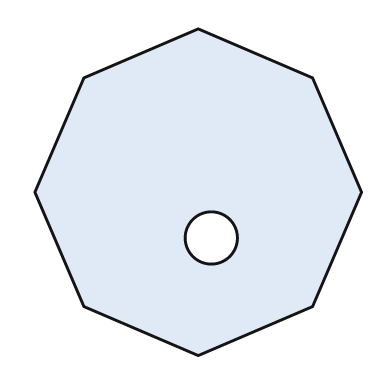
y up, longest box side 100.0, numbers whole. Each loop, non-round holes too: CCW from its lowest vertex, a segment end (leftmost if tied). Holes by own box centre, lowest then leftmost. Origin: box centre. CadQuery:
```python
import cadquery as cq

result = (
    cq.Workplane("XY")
    .moveTo(0.0, -50.0)
    .lineTo(35.0, -35.0)
    .lineTo(50.0, 0.0)
    .lineTo(35.0, 35.0)
    .lineTo(0.0, 50.0)
    .lineTo(-35.0, 35.0)
    .lineTo(-50.0, 0.0)
    .lineTo(-35.0, -35.0)
    .close()
    .moveTo(4.0, -14.0)
    .circle(8.0)
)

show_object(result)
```